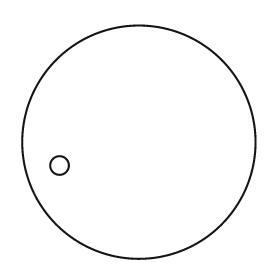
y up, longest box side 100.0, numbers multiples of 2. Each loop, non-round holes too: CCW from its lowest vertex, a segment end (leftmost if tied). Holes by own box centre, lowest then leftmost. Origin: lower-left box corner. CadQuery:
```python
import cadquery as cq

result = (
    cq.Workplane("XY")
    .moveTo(50.0, 50.0)
    .circle(50.0)
    .moveTo(16.0, 40.0)
    .circle(4.0)
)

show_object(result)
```